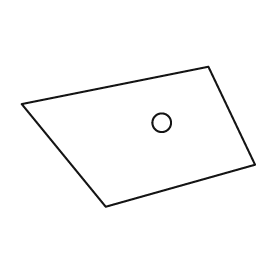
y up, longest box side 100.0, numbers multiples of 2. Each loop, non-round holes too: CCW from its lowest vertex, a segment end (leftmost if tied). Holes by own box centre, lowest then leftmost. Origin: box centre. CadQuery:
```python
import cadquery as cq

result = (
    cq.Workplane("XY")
    .moveTo(-14.0, -30.0)
    .lineTo(50.0, -12.0)
    .lineTo(30.0, 30.0)
    .lineTo(-50.0, 14.0)
    .close()
    .moveTo(10.0, 6.0)
    .circle(4.0)
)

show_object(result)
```